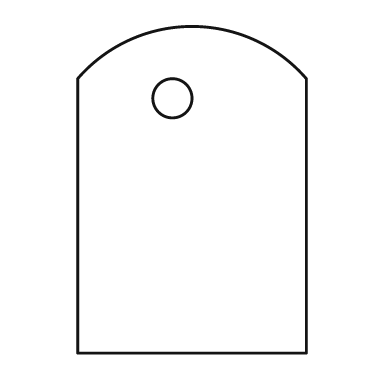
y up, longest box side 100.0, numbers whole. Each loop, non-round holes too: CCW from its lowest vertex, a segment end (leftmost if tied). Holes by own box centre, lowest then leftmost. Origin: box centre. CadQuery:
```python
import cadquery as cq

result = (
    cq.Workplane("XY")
    .moveTo(-35.0, -50.0)
    .lineTo(35.0, -50.0)
    .lineTo(35.0, 34.0)
    .threePointArc((0.0, 50.0), (-35.0, 34.0))
    .close()
    .moveTo(-6.0, 28.0)
    .circle(6.0)
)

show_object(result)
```